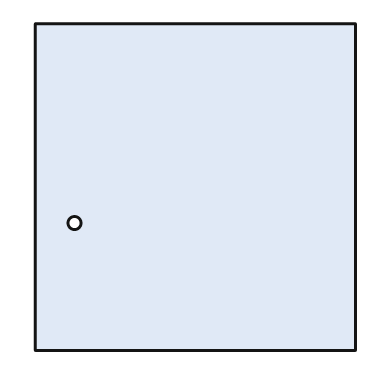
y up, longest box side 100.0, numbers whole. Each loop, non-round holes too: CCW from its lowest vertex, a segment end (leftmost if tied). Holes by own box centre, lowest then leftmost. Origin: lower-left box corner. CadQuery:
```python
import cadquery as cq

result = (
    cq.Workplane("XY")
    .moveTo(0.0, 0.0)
    .lineTo(98.0, 0.0)
    .lineTo(98.0, 100.0)
    .lineTo(0.0, 100.0)
    .close()
    .moveTo(12.0, 39.0)
    .circle(2.0)
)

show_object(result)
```